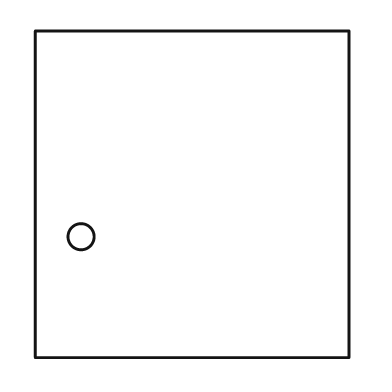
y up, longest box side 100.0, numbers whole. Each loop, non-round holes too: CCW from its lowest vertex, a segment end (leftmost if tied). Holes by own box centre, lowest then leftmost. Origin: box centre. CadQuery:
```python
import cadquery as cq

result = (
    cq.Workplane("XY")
    .moveTo(-48.0, -50.0)
    .lineTo(48.0, -50.0)
    .lineTo(48.0, 50.0)
    .lineTo(-48.0, 50.0)
    .close()
    .moveTo(-34.0, -13.0)
    .circle(4.0)
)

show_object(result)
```